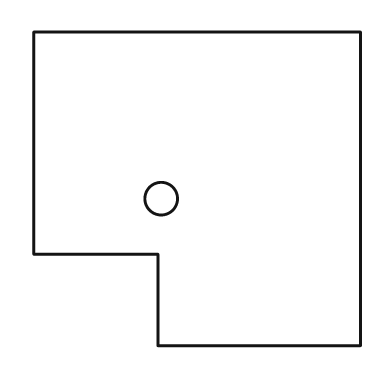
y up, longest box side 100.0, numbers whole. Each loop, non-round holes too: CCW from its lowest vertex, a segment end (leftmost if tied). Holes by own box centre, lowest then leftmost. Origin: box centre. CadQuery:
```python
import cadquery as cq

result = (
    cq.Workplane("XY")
    .moveTo(-12.0, -48.0)
    .lineTo(50.0, -48.0)
    .lineTo(50.0, 48.0)
    .lineTo(-50.0, 48.0)
    .lineTo(-50.0, -20.0)
    .lineTo(-12.0, -20.0)
    .close()
    .moveTo(-11.0, -3.0)
    .circle(5.0)
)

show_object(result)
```